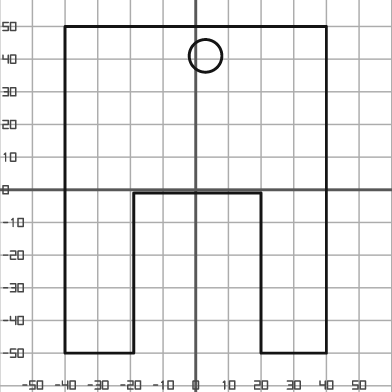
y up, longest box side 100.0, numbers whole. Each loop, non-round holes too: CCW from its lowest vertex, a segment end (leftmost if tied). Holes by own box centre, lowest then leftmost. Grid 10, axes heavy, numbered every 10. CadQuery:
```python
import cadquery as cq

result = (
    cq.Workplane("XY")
    .moveTo(-40.0, -50.0)
    .lineTo(-19.0, -50.0)
    .lineTo(-19.0, -1.0)
    .lineTo(20.0, -1.0)
    .lineTo(20.0, -50.0)
    .lineTo(40.0, -50.0)
    .lineTo(40.0, 50.0)
    .lineTo(-40.0, 50.0)
    .close()
    .moveTo(3.0, 41.0)
    .circle(5.0)
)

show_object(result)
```